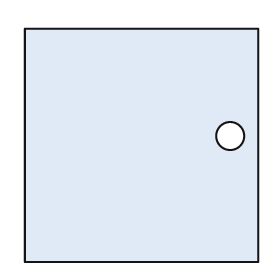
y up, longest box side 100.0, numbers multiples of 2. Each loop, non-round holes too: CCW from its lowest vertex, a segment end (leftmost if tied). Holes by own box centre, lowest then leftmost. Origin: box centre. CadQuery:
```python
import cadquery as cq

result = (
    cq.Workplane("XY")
    .moveTo(-50.0, -50.0)
    .lineTo(50.0, -50.0)
    .lineTo(50.0, 50.0)
    .lineTo(-50.0, 50.0)
    .close()
    .moveTo(38.0, 4.0)
    .circle(6.0)
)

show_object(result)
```